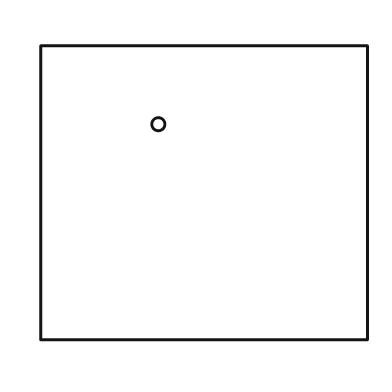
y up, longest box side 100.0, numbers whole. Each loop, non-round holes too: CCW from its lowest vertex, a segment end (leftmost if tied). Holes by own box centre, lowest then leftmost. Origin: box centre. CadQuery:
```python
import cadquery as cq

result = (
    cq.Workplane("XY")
    .moveTo(-50.0, -45.0)
    .lineTo(50.0, -45.0)
    .lineTo(50.0, 45.0)
    .lineTo(-50.0, 45.0)
    .close()
    .moveTo(-14.0, 21.0)
    .circle(2.0)
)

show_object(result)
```